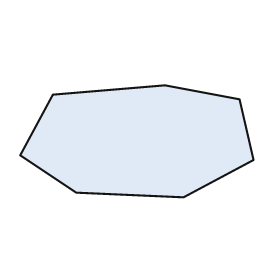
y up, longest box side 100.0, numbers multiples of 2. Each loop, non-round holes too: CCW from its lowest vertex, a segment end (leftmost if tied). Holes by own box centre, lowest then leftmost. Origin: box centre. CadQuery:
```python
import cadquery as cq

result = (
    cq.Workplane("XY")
    .moveTo(20.0, -24.0)
    .lineTo(50.0, -8.0)
    .lineTo(44.0, 18.0)
    .lineTo(12.0, 24.0)
    .lineTo(-36.0, 20.0)
    .lineTo(-50.0, -6.0)
    .lineTo(-26.0, -22.0)
    .close()
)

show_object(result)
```